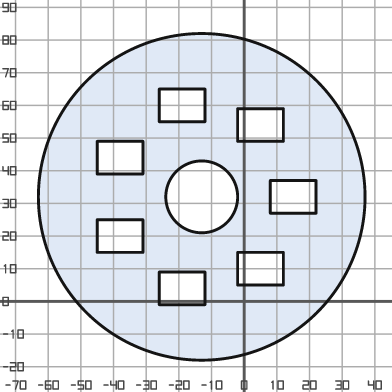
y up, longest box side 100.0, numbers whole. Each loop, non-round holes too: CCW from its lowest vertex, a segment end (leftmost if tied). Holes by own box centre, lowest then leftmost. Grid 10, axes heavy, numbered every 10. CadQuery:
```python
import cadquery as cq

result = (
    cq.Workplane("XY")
    .moveTo(-13.0, 32.0)
    .circle(50.0)
    .moveTo(-26.0, -1.0)
    .lineTo(-12.0, -1.0)
    .lineTo(-12.0, 9.0)
    .lineTo(-26.0, 9.0)
    .close()
    .moveTo(-2.0, 5.0)
    .lineTo(12.0, 5.0)
    .lineTo(12.0, 15.0)
    .lineTo(-2.0, 15.0)
    .close()
    .moveTo(-45.0, 15.0)
    .lineTo(-31.0, 15.0)
    .lineTo(-31.0, 25.0)
    .lineTo(-45.0, 25.0)
    .close()
    .moveTo(-13.0, 32.0)
    .circle(11.0)
    .moveTo(8.0, 27.0)
    .lineTo(22.0, 27.0)
    .lineTo(22.0, 37.0)
    .lineTo(8.0, 37.0)
    .close()
    .moveTo(-45.0, 39.0)
    .lineTo(-31.0, 39.0)
    .lineTo(-31.0, 49.0)
    .lineTo(-45.0, 49.0)
    .close()
    .moveTo(-2.0, 49.0)
    .lineTo(12.0, 49.0)
    .lineTo(12.0, 59.0)
    .lineTo(-2.0, 59.0)
    .close()
    .moveTo(-26.0, 55.0)
    .lineTo(-12.0, 55.0)
    .lineTo(-12.0, 65.0)
    .lineTo(-26.0, 65.0)
    .close()
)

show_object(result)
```